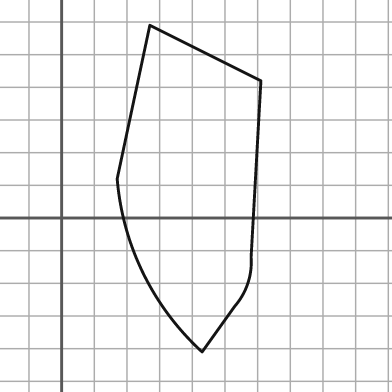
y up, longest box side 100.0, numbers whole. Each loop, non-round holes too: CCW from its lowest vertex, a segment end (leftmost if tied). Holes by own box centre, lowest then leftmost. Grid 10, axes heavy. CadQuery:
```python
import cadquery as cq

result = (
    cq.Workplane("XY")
    .moveTo(43.0, -41.0)
    .lineTo(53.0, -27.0)
    .threePointArc((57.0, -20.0), (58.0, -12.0))
    .lineTo(61.0, 42.0)
    .lineTo(27.0, 59.0)
    .lineTo(17.0, 12.0)
    .threePointArc((25.0, -17.0), (43.0, -41.0))
    .close()
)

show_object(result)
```